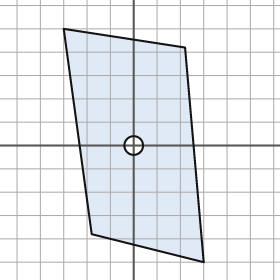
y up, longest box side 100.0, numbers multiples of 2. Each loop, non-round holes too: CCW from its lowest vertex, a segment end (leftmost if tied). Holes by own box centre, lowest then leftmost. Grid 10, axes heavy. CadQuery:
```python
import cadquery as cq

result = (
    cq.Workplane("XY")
    .moveTo(30.0, -50.0)
    .lineTo(22.0, 42.0)
    .lineTo(-30.0, 50.0)
    .lineTo(-18.0, -38.0)
    .close()
    .moveTo(0.0, 0.0)
    .circle(4.0)
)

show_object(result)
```